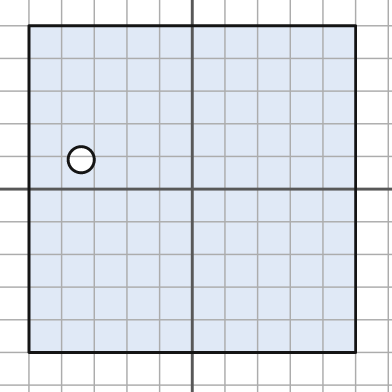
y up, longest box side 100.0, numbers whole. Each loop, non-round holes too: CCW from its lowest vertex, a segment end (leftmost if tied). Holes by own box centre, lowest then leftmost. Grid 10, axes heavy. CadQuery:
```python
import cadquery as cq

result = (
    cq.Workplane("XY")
    .moveTo(-50.0, -50.0)
    .lineTo(50.0, -50.0)
    .lineTo(50.0, 50.0)
    .lineTo(-50.0, 50.0)
    .close()
    .moveTo(-34.0, 9.0)
    .circle(4.0)
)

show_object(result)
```